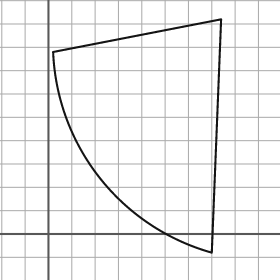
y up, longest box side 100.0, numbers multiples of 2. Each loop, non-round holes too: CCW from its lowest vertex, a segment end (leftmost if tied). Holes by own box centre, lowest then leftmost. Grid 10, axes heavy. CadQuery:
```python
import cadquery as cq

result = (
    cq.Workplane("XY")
    .moveTo(70.0, -8.0)
    .lineTo(74.0, 92.0)
    .lineTo(2.0, 78.0)
    .threePointArc((22.0, 24.0), (70.0, -8.0))
    .close()
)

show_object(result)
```